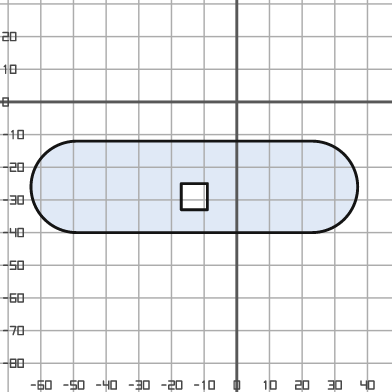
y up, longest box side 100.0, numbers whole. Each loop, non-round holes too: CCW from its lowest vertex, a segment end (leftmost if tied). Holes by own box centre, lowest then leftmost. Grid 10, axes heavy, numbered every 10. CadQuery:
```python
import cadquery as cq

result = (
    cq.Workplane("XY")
    .moveTo(-49.0, -40.0)
    .lineTo(23.0, -40.0)
    .threePointArc((37.0, -26.0), (23.0, -12.0))
    .lineTo(-49.0, -12.0)
    .threePointArc((-63.0, -26.0), (-49.0, -40.0))
    .close()
    .moveTo(-17.0, -33.0)
    .lineTo(-9.0, -33.0)
    .lineTo(-9.0, -25.0)
    .lineTo(-17.0, -25.0)
    .close()
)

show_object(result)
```